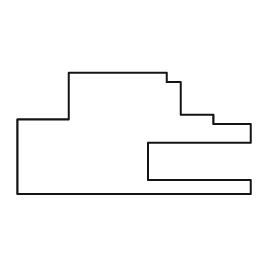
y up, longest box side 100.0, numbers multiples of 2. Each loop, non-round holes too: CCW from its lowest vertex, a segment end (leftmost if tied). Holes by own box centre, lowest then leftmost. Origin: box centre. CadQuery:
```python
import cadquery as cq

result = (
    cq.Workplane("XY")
    .moveTo(-50.0, -26.0)
    .lineTo(50.0, -26.0)
    .lineTo(50.0, -20.0)
    .lineTo(6.0, -20.0)
    .lineTo(6.0, -4.0)
    .lineTo(50.0, -4.0)
    .lineTo(50.0, 4.0)
    .lineTo(34.0, 4.0)
    .lineTo(34.0, 8.0)
    .lineTo(20.0, 8.0)
    .lineTo(20.0, 22.0)
    .lineTo(14.0, 22.0)
    .lineTo(14.0, 26.0)
    .lineTo(-28.0, 26.0)
    .lineTo(-28.0, 6.0)
    .lineTo(-50.0, 6.0)
    .close()
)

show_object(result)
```